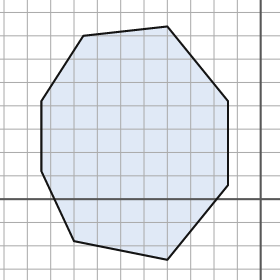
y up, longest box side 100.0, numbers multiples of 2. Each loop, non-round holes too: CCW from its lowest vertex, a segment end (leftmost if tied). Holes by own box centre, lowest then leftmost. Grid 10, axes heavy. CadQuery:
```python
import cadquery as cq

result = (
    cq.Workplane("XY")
    .moveTo(-40.0, -26.0)
    .lineTo(-14.0, 6.0)
    .lineTo(-14.0, 42.0)
    .lineTo(-40.0, 74.0)
    .lineTo(-76.0, 70.0)
    .lineTo(-94.0, 42.0)
    .lineTo(-94.0, 12.0)
    .lineTo(-80.0, -18.0)
    .close()
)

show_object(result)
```